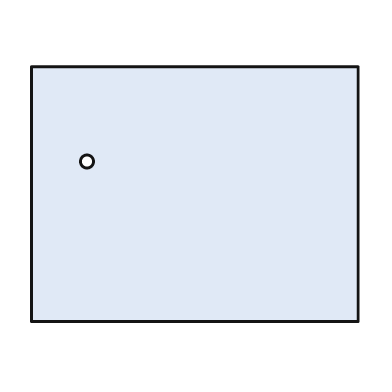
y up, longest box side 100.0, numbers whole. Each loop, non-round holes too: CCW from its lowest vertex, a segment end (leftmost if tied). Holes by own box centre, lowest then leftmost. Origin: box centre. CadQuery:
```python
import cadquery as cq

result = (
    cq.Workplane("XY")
    .moveTo(-50.0, -39.0)
    .lineTo(50.0, -39.0)
    .lineTo(50.0, 39.0)
    .lineTo(-50.0, 39.0)
    .close()
    .moveTo(-33.0, 10.0)
    .circle(2.0)
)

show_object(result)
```